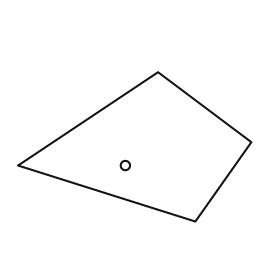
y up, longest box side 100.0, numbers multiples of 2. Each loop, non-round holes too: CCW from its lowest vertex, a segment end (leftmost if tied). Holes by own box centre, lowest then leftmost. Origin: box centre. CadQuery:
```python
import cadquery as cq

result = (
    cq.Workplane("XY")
    .moveTo(26.0, -32.0)
    .lineTo(50.0, 2.0)
    .lineTo(10.0, 32.0)
    .lineTo(-50.0, -8.0)
    .close()
    .moveTo(-4.0, -8.0)
    .circle(2.0)
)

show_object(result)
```